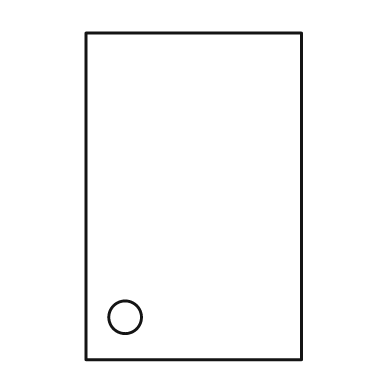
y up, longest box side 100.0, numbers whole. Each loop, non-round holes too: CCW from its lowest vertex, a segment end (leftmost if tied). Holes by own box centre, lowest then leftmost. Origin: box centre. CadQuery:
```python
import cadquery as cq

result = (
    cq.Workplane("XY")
    .moveTo(-33.0, -50.0)
    .lineTo(33.0, -50.0)
    .lineTo(33.0, 50.0)
    .lineTo(-33.0, 50.0)
    .close()
    .moveTo(-21.0, -37.0)
    .circle(5.0)
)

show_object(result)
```